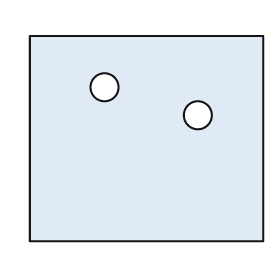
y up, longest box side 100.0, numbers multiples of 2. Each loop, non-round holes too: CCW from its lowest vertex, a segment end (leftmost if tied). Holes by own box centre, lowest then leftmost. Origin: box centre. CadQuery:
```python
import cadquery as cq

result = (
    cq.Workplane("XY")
    .moveTo(-50.0, -44.0)
    .lineTo(50.0, -44.0)
    .lineTo(50.0, 44.0)
    .lineTo(-50.0, 44.0)
    .close()
    .moveTo(22.0, 10.0)
    .circle(6.0)
    .moveTo(-18.0, 22.0)
    .circle(6.0)
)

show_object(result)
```